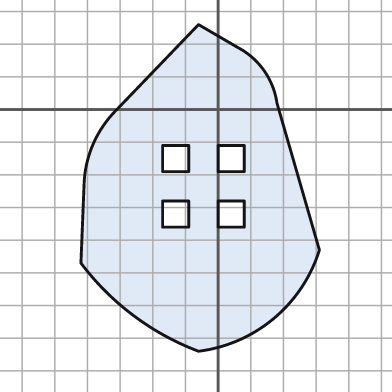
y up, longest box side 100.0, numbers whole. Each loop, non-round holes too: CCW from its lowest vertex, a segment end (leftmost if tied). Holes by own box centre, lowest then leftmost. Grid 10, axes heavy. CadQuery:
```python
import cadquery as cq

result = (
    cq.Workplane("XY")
    .moveTo(-6.0, -74.0)
    .threePointArc((17.0, -64.0), (31.0, -43.0))
    .lineTo(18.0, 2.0)
    .threePointArc((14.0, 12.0), (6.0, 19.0))
    .lineTo(-6.0, 26.0)
    .lineTo(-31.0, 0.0)
    .threePointArc((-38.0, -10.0), (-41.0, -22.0))
    .lineTo(-42.0, -47.0)
    .threePointArc((-26.0, -63.0), (-6.0, -74.0))
    .close()
    .moveTo(-17.0, -36.0)
    .lineTo(-9.0, -36.0)
    .lineTo(-9.0, -28.0)
    .lineTo(-17.0, -28.0)
    .close()
    .moveTo(0.0, -36.0)
    .lineTo(8.0, -36.0)
    .lineTo(8.0, -28.0)
    .lineTo(0.0, -28.0)
    .close()
    .moveTo(-17.0, -19.0)
    .lineTo(-9.0, -19.0)
    .lineTo(-9.0, -11.0)
    .lineTo(-17.0, -11.0)
    .close()
    .moveTo(0.0, -19.0)
    .lineTo(8.0, -19.0)
    .lineTo(8.0, -11.0)
    .lineTo(0.0, -11.0)
    .close()
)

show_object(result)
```